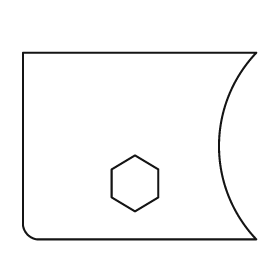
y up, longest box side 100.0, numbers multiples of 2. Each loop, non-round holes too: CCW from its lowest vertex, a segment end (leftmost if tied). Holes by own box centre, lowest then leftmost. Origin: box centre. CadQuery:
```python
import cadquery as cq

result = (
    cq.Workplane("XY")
    .moveTo(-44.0, -40.0)
    .lineTo(50.0, -40.0)
    .threePointArc((34.0, 0.0), (50.0, 40.0))
    .lineTo(-50.0, 40.0)
    .lineTo(-50.0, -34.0)
    .threePointArc((-48.0, -38.0), (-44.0, -40.0))
    .close()
    .moveTo(-2.0, -28.0)
    .lineTo(8.0, -22.0)
    .lineTo(8.0, -10.0)
    .lineTo(-2.0, -4.0)
    .lineTo(-12.0, -10.0)
    .lineTo(-12.0, -22.0)
    .close()
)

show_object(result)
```